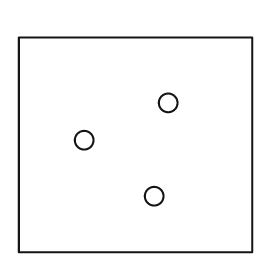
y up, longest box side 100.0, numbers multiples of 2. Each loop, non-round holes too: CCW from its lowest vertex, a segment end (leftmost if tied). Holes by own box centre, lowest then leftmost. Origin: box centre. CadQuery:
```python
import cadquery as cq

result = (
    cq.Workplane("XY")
    .moveTo(-50.0, -46.0)
    .lineTo(50.0, -46.0)
    .lineTo(50.0, 46.0)
    .lineTo(-50.0, 46.0)
    .close()
    .moveTo(8.0, -22.0)
    .circle(4.0)
    .moveTo(-22.0, 2.0)
    .circle(4.0)
    .moveTo(14.0, 18.0)
    .circle(4.0)
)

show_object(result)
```